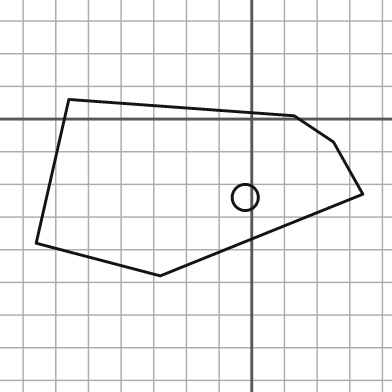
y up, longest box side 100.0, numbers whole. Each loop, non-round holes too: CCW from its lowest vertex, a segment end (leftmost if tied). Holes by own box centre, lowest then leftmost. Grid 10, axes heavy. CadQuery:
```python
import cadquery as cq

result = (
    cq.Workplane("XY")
    .moveTo(-28.0, -48.0)
    .lineTo(34.0, -23.0)
    .lineTo(25.0, -7.0)
    .lineTo(13.0, 1.0)
    .lineTo(-56.0, 6.0)
    .lineTo(-66.0, -38.0)
    .close()
    .moveTo(-2.0, -24.0)
    .circle(4.0)
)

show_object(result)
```